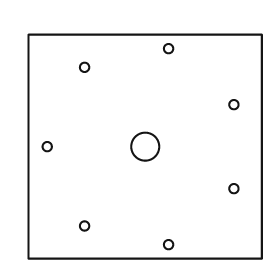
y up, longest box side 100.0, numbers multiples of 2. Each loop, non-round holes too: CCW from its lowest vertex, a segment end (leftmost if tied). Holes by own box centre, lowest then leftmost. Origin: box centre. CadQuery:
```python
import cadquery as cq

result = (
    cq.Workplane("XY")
    .moveTo(-50.0, -48.0)
    .lineTo(50.0, -48.0)
    .lineTo(50.0, 48.0)
    .lineTo(-50.0, 48.0)
    .close()
    .moveTo(10.0, -42.0)
    .circle(2.0)
    .moveTo(-26.0, -34.0)
    .circle(2.0)
    .moveTo(38.0, -18.0)
    .circle(2.0)
    .moveTo(-42.0, 0.0)
    .circle(2.0)
    .moveTo(0.0, 0.0)
    .circle(6.0)
    .moveTo(38.0, 18.0)
    .circle(2.0)
    .moveTo(-26.0, 34.0)
    .circle(2.0)
    .moveTo(10.0, 42.0)
    .circle(2.0)
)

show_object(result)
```